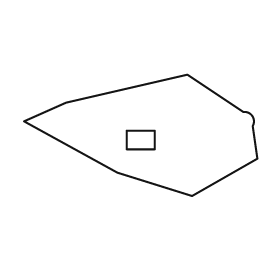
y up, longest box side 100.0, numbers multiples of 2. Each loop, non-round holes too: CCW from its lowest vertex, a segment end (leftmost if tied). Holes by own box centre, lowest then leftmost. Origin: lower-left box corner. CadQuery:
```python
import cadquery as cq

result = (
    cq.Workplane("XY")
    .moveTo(72.0, 0.0)
    .lineTo(100.0, 16.0)
    .lineTo(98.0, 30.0)
    .threePointArc((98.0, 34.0), (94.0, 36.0))
    .lineTo(70.0, 52.0)
    .lineTo(18.0, 40.0)
    .lineTo(0.0, 32.0)
    .lineTo(40.0, 10.0)
    .close()
    .moveTo(44.0, 20.0)
    .lineTo(56.0, 20.0)
    .lineTo(56.0, 28.0)
    .lineTo(44.0, 28.0)
    .close()
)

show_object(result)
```